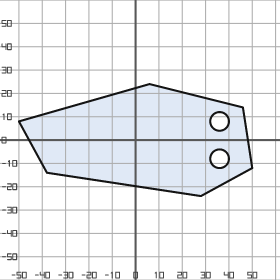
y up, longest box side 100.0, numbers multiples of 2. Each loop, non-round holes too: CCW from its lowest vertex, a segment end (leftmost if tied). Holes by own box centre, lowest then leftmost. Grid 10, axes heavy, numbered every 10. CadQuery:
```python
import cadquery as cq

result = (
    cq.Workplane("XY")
    .moveTo(28.0, -24.0)
    .lineTo(50.0, -12.0)
    .lineTo(46.0, 14.0)
    .lineTo(6.0, 24.0)
    .lineTo(-50.0, 8.0)
    .lineTo(-38.0, -14.0)
    .close()
    .moveTo(36.0, -8.0)
    .circle(4.0)
    .moveTo(36.0, 8.0)
    .circle(4.0)
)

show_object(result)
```